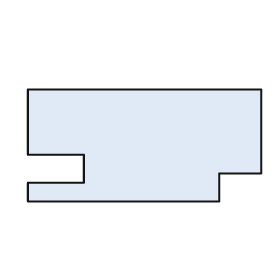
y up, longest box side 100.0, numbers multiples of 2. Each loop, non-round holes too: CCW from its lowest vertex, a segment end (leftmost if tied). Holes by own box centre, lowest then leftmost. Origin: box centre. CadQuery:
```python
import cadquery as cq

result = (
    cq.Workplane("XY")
    .moveTo(-50.0, -24.0)
    .lineTo(32.0, -24.0)
    .lineTo(32.0, -12.0)
    .lineTo(50.0, -12.0)
    .lineTo(50.0, 24.0)
    .lineTo(-50.0, 24.0)
    .lineTo(-50.0, -4.0)
    .lineTo(-26.0, -4.0)
    .lineTo(-26.0, -16.0)
    .lineTo(-50.0, -16.0)
    .close()
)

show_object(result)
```